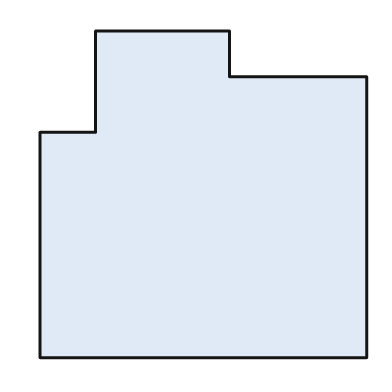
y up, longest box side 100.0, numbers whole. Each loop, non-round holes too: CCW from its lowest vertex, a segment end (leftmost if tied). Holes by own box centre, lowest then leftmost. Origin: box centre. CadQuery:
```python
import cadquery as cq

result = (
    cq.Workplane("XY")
    .moveTo(-50.0, -50.0)
    .lineTo(50.0, -50.0)
    .lineTo(50.0, 36.0)
    .lineTo(8.0, 36.0)
    .lineTo(8.0, 50.0)
    .lineTo(-33.0, 50.0)
    .lineTo(-33.0, 19.0)
    .lineTo(-50.0, 19.0)
    .close()
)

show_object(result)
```